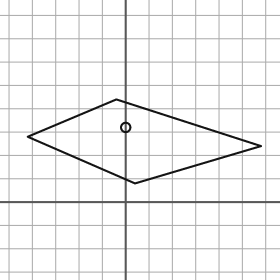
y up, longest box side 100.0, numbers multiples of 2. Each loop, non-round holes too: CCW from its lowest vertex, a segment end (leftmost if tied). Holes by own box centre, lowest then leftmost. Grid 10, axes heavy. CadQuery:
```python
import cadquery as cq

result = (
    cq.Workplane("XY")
    .moveTo(4.0, 8.0)
    .lineTo(58.0, 24.0)
    .lineTo(-4.0, 44.0)
    .lineTo(-42.0, 28.0)
    .close()
    .moveTo(0.0, 32.0)
    .circle(2.0)
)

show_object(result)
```